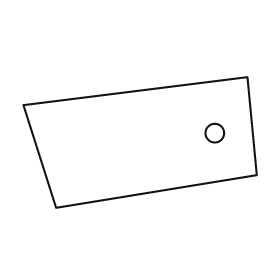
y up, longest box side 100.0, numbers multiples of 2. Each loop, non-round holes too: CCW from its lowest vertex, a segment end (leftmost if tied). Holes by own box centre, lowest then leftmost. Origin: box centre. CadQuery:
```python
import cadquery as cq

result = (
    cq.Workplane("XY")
    .moveTo(-36.0, -28.0)
    .lineTo(50.0, -14.0)
    .lineTo(46.0, 28.0)
    .lineTo(-50.0, 16.0)
    .close()
    .moveTo(32.0, 4.0)
    .circle(4.0)
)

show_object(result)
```